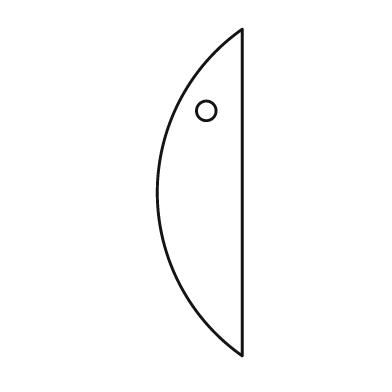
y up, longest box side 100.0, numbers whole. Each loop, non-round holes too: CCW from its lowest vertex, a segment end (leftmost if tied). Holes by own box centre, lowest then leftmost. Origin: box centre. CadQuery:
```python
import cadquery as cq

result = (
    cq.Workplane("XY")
    .moveTo(13.0, -50.0)
    .lineTo(13.0, 50.0)
    .threePointArc((-13.0, 0.0), (13.0, -50.0))
    .close()
    .moveTo(2.0, 25.0)
    .circle(3.0)
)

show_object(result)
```